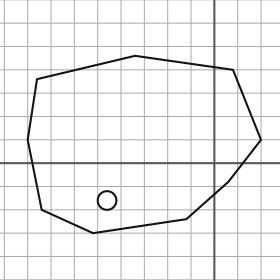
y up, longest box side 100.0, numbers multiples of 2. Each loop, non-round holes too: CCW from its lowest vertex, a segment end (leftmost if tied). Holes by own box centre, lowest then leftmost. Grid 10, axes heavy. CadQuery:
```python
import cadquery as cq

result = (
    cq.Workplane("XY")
    .moveTo(-52.0, -30.0)
    .lineTo(-12.0, -24.0)
    .lineTo(6.0, -8.0)
    .lineTo(20.0, 10.0)
    .lineTo(8.0, 40.0)
    .lineTo(-34.0, 46.0)
    .lineTo(-76.0, 36.0)
    .lineTo(-80.0, 10.0)
    .lineTo(-74.0, -20.0)
    .close()
    .moveTo(-46.0, -16.0)
    .circle(4.0)
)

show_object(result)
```